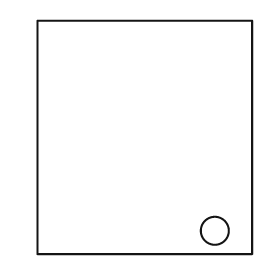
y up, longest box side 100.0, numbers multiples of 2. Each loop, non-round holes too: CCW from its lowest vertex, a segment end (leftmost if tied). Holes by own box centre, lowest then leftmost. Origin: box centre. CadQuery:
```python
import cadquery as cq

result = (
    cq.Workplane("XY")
    .moveTo(-46.0, -50.0)
    .lineTo(46.0, -50.0)
    .lineTo(46.0, 50.0)
    .lineTo(-46.0, 50.0)
    .close()
    .moveTo(30.0, -40.0)
    .circle(6.0)
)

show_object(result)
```